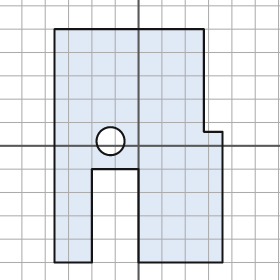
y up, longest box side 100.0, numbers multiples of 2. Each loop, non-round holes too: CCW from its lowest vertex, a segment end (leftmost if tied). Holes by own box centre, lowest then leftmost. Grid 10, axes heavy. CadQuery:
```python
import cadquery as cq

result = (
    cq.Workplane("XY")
    .moveTo(-36.0, -50.0)
    .lineTo(-20.0, -50.0)
    .lineTo(-20.0, -10.0)
    .lineTo(0.0, -10.0)
    .lineTo(0.0, -50.0)
    .lineTo(36.0, -50.0)
    .lineTo(36.0, 6.0)
    .lineTo(28.0, 6.0)
    .lineTo(28.0, 50.0)
    .lineTo(-36.0, 50.0)
    .close()
    .moveTo(-12.0, 2.0)
    .circle(6.0)
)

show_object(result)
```